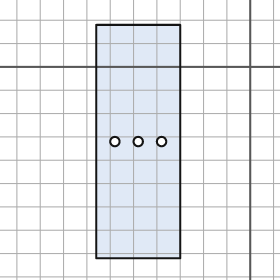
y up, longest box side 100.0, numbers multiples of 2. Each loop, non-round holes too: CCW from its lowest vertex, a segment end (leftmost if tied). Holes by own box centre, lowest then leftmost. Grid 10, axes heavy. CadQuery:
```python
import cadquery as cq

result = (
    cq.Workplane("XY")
    .moveTo(-66.0, -82.0)
    .lineTo(-30.0, -82.0)
    .lineTo(-30.0, 18.0)
    .lineTo(-66.0, 18.0)
    .close()
    .moveTo(-58.0, -32.0)
    .circle(2.0)
    .moveTo(-48.0, -32.0)
    .circle(2.0)
    .moveTo(-38.0, -32.0)
    .circle(2.0)
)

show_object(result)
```